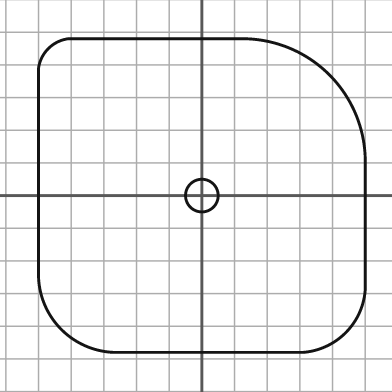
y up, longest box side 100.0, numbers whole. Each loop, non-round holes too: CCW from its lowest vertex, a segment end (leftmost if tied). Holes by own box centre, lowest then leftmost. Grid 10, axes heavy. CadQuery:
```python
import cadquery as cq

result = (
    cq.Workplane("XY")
    .moveTo(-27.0, -48.0)
    .lineTo(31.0, -48.0)
    .threePointArc((44.0, -42.0), (50.0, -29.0))
    .lineTo(50.0, 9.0)
    .threePointArc((39.0, 37.0), (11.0, 48.0))
    .lineTo(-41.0, 48.0)
    .threePointArc((-47.0, 45.0), (-50.0, 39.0))
    .lineTo(-50.0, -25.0)
    .threePointArc((-43.0, -41.0), (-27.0, -48.0))
    .close()
    .moveTo(0.0, 0.0)
    .circle(5.0)
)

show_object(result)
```